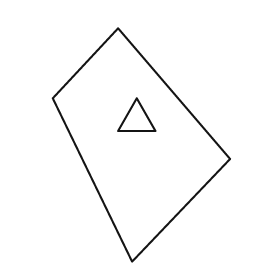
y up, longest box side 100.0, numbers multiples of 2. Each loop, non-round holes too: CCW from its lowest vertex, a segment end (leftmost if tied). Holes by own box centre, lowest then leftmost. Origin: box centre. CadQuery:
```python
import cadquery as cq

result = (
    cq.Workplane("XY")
    .moveTo(-4.0, -50.0)
    .lineTo(38.0, -6.0)
    .lineTo(-10.0, 50.0)
    .lineTo(-38.0, 20.0)
    .close()
    .moveTo(-10.0, 6.0)
    .lineTo(6.0, 6.0)
    .lineTo(-2.0, 20.0)
    .close()
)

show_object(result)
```